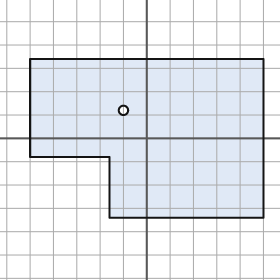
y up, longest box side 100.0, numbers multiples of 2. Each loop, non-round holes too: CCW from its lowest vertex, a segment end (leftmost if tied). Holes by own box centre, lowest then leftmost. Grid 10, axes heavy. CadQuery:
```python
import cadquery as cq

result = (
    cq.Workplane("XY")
    .moveTo(-16.0, -34.0)
    .lineTo(50.0, -34.0)
    .lineTo(50.0, 34.0)
    .lineTo(-50.0, 34.0)
    .lineTo(-50.0, -8.0)
    .lineTo(-16.0, -8.0)
    .close()
    .moveTo(-10.0, 12.0)
    .circle(2.0)
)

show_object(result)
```